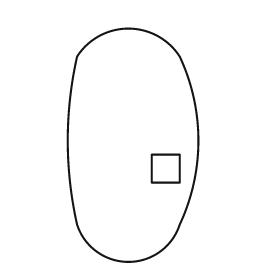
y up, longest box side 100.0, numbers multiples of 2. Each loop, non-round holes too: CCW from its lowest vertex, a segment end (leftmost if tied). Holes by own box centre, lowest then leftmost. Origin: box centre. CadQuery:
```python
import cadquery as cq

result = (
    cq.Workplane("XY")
    .moveTo(-24.0, -34.0)
    .threePointArc((-2.0, -50.0), (20.0, -34.0))
    .threePointArc((28.0, 2.0), (20.0, 38.0))
    .threePointArc((-2.0, 50.0), (-24.0, 38.0))
    .threePointArc((-28.0, 2.0), (-24.0, -34.0))
    .close()
    .moveTo(8.0, -16.0)
    .lineTo(20.0, -16.0)
    .lineTo(20.0, -4.0)
    .lineTo(8.0, -4.0)
    .close()
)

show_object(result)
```